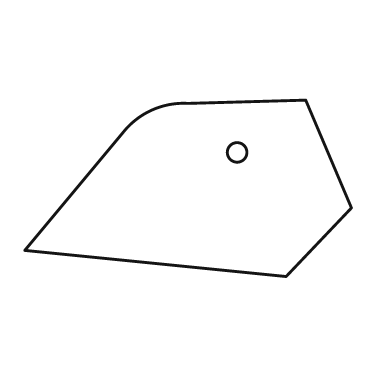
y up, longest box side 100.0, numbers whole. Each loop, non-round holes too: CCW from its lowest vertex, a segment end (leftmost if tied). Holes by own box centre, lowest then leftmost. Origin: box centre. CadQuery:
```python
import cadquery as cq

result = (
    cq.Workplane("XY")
    .moveTo(30.0, -27.0)
    .lineTo(50.0, -6.0)
    .lineTo(36.0, 27.0)
    .lineTo(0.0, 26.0)
    .threePointArc((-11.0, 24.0), (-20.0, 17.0))
    .lineTo(-50.0, -19.0)
    .close()
    .moveTo(15.0, 11.0)
    .circle(3.0)
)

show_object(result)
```